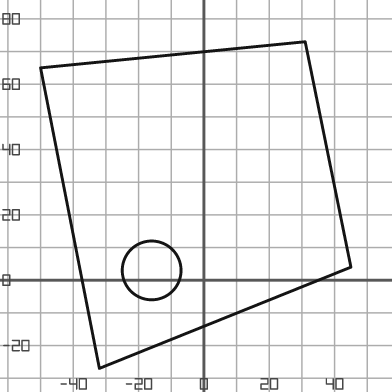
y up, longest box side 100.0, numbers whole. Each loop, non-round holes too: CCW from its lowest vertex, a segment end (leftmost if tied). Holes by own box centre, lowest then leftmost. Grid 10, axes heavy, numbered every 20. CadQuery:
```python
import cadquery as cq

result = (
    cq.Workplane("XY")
    .moveTo(-32.0, -27.0)
    .lineTo(45.0, 4.0)
    .lineTo(31.0, 73.0)
    .lineTo(-50.0, 65.0)
    .close()
    .moveTo(-16.0, 3.0)
    .circle(9.0)
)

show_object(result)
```